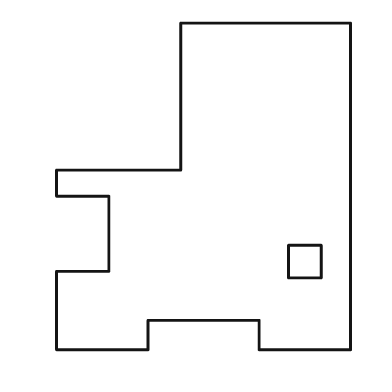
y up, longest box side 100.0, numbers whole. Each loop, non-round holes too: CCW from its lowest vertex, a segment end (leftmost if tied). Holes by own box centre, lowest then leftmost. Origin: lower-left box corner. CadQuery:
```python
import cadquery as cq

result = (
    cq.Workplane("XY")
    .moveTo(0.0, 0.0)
    .lineTo(28.0, 0.0)
    .lineTo(28.0, 9.0)
    .lineTo(62.0, 9.0)
    .lineTo(62.0, 0.0)
    .lineTo(90.0, 0.0)
    .lineTo(90.0, 100.0)
    .lineTo(38.0, 100.0)
    .lineTo(38.0, 55.0)
    .lineTo(0.0, 55.0)
    .lineTo(0.0, 47.0)
    .lineTo(16.0, 47.0)
    .lineTo(16.0, 24.0)
    .lineTo(0.0, 24.0)
    .close()
    .moveTo(71.0, 22.0)
    .lineTo(81.0, 22.0)
    .lineTo(81.0, 32.0)
    .lineTo(71.0, 32.0)
    .close()
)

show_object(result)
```